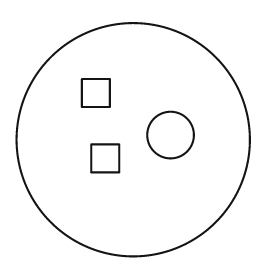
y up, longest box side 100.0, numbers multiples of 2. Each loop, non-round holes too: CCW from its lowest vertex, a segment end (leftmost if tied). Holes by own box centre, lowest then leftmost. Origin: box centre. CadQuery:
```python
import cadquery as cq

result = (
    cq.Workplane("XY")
    .moveTo(0.0, 0.0)
    .circle(50.0)
    .moveTo(-18.0, -14.0)
    .lineTo(-6.0, -14.0)
    .lineTo(-6.0, -2.0)
    .lineTo(-18.0, -2.0)
    .close()
    .moveTo(16.0, 2.0)
    .circle(10.0)
    .moveTo(-22.0, 14.0)
    .lineTo(-10.0, 14.0)
    .lineTo(-10.0, 26.0)
    .lineTo(-22.0, 26.0)
    .close()
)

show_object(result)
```